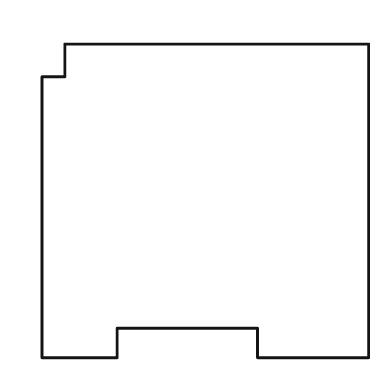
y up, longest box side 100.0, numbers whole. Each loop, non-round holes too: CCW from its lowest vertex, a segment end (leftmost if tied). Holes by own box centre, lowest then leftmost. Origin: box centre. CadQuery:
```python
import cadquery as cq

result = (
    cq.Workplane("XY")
    .moveTo(-50.0, -48.0)
    .lineTo(-27.0, -48.0)
    .lineTo(-27.0, -39.0)
    .lineTo(16.0, -39.0)
    .lineTo(16.0, -48.0)
    .lineTo(50.0, -48.0)
    .lineTo(50.0, 48.0)
    .lineTo(-43.0, 48.0)
    .lineTo(-43.0, 38.0)
    .lineTo(-50.0, 38.0)
    .close()
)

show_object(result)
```